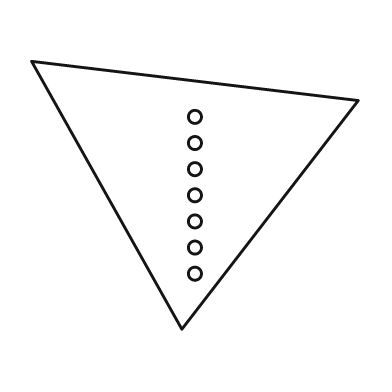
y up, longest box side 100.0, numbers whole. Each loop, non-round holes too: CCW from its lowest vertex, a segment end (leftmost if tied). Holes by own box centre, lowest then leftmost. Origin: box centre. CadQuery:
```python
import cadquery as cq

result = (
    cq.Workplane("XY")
    .moveTo(-4.0, -41.0)
    .lineTo(50.0, 29.0)
    .lineTo(-50.0, 41.0)
    .close()
    .moveTo(0.0, -24.0)
    .circle(2.0)
    .moveTo(0.0, -16.0)
    .circle(2.0)
    .moveTo(0.0, -8.0)
    .circle(2.0)
    .moveTo(0.0, 0.0)
    .circle(2.0)
    .moveTo(0.0, 8.0)
    .circle(2.0)
    .moveTo(0.0, 16.0)
    .circle(2.0)
    .moveTo(0.0, 24.0)
    .circle(2.0)
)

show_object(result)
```